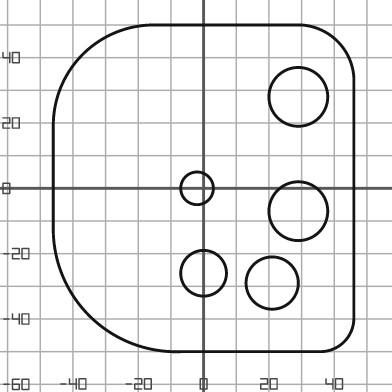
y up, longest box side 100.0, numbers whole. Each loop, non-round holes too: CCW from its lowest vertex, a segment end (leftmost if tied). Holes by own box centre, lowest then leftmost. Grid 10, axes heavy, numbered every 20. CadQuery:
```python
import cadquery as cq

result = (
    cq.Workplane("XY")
    .moveTo(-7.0, -50.0)
    .lineTo(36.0, -50.0)
    .threePointArc((43.0, -47.0), (46.0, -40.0))
    .lineTo(46.0, 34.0)
    .threePointArc((41.0, 45.0), (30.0, 50.0))
    .lineTo(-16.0, 50.0)
    .threePointArc((-37.0, 41.0), (-46.0, 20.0))
    .lineTo(-46.0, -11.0)
    .threePointArc((-35.0, -39.0), (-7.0, -50.0))
    .close()
    .moveTo(21.0, -29.0)
    .circle(8.0)
    .moveTo(0.0, -26.0)
    .circle(7.0)
    .moveTo(29.0, -7.0)
    .circle(9.0)
    .moveTo(-2.0, 0.0)
    .circle(5.0)
    .moveTo(29.0, 28.0)
    .circle(9.0)
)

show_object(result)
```